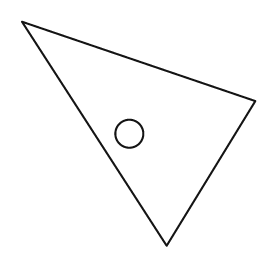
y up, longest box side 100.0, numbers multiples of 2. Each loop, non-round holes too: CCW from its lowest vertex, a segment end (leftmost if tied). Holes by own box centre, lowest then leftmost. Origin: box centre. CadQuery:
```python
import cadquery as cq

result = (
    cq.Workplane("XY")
    .moveTo(12.0, -48.0)
    .lineTo(50.0, 14.0)
    .lineTo(-50.0, 48.0)
    .close()
    .moveTo(-4.0, 0.0)
    .circle(6.0)
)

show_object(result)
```